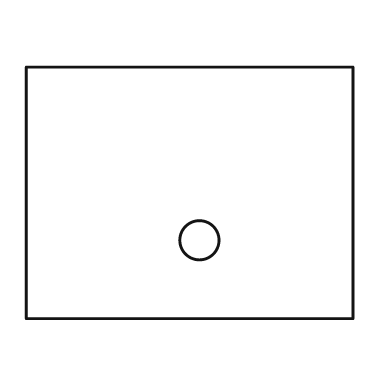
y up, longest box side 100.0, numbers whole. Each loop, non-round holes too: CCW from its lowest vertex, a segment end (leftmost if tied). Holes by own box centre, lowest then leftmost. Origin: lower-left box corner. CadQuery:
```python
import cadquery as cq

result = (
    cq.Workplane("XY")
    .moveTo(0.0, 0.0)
    .lineTo(100.0, 0.0)
    .lineTo(100.0, 77.0)
    .lineTo(0.0, 77.0)
    .close()
    .moveTo(53.0, 24.0)
    .circle(6.0)
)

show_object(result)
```